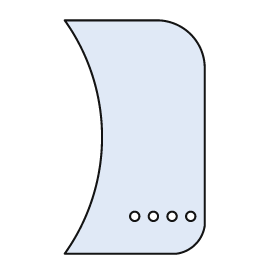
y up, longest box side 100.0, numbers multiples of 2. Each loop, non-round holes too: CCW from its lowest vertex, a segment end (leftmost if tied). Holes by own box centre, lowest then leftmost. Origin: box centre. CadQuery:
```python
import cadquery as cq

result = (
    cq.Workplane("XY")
    .moveTo(-30.0, -50.0)
    .lineTo(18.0, -50.0)
    .threePointArc((26.0, -46.0), (30.0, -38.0))
    .lineTo(30.0, 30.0)
    .threePointArc((24.0, 44.0), (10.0, 50.0))
    .lineTo(-30.0, 50.0)
    .threePointArc((-14.0, 0.0), (-30.0, -50.0))
    .close()
    .moveTo(0.0, -34.0)
    .circle(2.0)
    .moveTo(8.0, -34.0)
    .circle(2.0)
    .moveTo(16.0, -34.0)
    .circle(2.0)
    .moveTo(24.0, -34.0)
    .circle(2.0)
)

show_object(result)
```